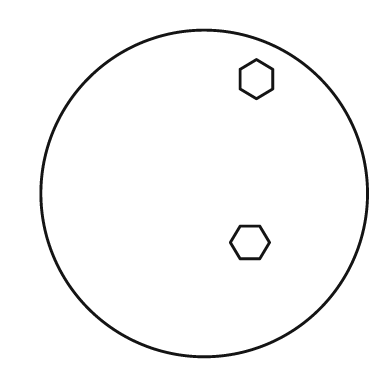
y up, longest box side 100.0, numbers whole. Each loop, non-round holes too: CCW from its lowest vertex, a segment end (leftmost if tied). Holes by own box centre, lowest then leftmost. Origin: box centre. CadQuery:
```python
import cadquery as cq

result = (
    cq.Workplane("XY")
    .moveTo(0.0, 0.0)
    .circle(50.0)
    .moveTo(11.0, -20.0)
    .lineTo(17.0, -20.0)
    .lineTo(20.0, -15.0)
    .lineTo(17.0, -10.0)
    .lineTo(11.0, -10.0)
    .lineTo(8.0, -15.0)
    .close()
    .moveTo(16.0, 29.0)
    .lineTo(21.0, 32.0)
    .lineTo(21.0, 38.0)
    .lineTo(16.0, 41.0)
    .lineTo(11.0, 38.0)
    .lineTo(11.0, 32.0)
    .close()
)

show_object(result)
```